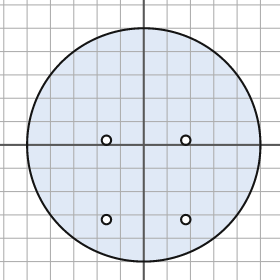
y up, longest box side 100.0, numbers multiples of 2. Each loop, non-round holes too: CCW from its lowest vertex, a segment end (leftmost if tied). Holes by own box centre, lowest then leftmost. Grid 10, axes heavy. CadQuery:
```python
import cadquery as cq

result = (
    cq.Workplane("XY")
    .moveTo(0.0, 0.0)
    .circle(50.0)
    .moveTo(-16.0, -32.0)
    .circle(2.0)
    .moveTo(18.0, -32.0)
    .circle(2.0)
    .moveTo(-16.0, 2.0)
    .circle(2.0)
    .moveTo(18.0, 2.0)
    .circle(2.0)
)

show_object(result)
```